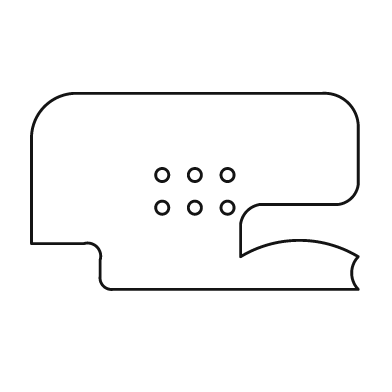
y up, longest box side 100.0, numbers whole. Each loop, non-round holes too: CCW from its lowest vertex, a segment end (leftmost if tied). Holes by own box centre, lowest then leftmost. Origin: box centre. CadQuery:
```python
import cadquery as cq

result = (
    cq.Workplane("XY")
    .moveTo(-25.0, -30.0)
    .lineTo(50.0, -30.0)
    .threePointArc((48.0, -25.0), (50.0, -20.0))
    .threePointArc((32.0, -15.0), (14.0, -20.0))
    .lineTo(14.0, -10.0)
    .threePointArc((16.0, -6.0), (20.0, -4.0))
    .lineTo(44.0, -4.0)
    .threePointArc((48.0, -2.0), (50.0, 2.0))
    .lineTo(50.0, 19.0)
    .threePointArc((47.0, 27.0), (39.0, 30.0))
    .lineTo(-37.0, 30.0)
    .threePointArc((-46.0, 26.0), (-50.0, 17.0))
    .lineTo(-50.0, -16.0)
    .lineTo(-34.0, -16.0)
    .threePointArc((-30.0, -17.0), (-29.0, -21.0))
    .lineTo(-29.0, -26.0)
    .threePointArc((-28.0, -29.0), (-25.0, -30.0))
    .close()
    .moveTo(-10.0, -5.0)
    .circle(2.0)
    .moveTo(0.0, -5.0)
    .circle(2.0)
    .moveTo(10.0, -5.0)
    .circle(2.0)
    .moveTo(-10.0, 5.0)
    .circle(2.0)
    .moveTo(0.0, 5.0)
    .circle(2.0)
    .moveTo(10.0, 5.0)
    .circle(2.0)
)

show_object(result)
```